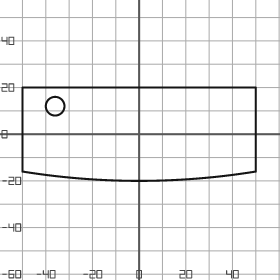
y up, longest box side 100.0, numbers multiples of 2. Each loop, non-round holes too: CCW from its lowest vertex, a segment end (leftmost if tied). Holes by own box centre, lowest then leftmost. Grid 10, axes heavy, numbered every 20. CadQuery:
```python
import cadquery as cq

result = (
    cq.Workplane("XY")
    .moveTo(-50.0, -16.0)
    .threePointArc((0.0, -20.0), (50.0, -16.0))
    .lineTo(50.0, 20.0)
    .lineTo(-50.0, 20.0)
    .close()
    .moveTo(-36.0, 12.0)
    .circle(4.0)
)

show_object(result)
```